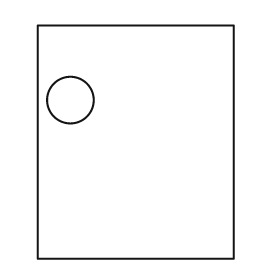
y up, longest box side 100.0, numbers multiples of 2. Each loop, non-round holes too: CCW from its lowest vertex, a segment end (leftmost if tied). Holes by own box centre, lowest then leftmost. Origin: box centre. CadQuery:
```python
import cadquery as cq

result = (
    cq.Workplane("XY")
    .moveTo(-42.0, -50.0)
    .lineTo(42.0, -50.0)
    .lineTo(42.0, 50.0)
    .lineTo(-42.0, 50.0)
    .close()
    .moveTo(-28.0, 18.0)
    .circle(10.0)
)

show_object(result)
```